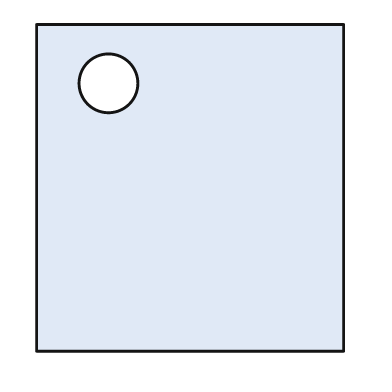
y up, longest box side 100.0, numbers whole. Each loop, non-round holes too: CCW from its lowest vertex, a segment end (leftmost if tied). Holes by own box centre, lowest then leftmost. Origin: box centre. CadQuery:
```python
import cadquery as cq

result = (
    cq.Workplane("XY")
    .moveTo(-47.0, -50.0)
    .lineTo(47.0, -50.0)
    .lineTo(47.0, 50.0)
    .lineTo(-47.0, 50.0)
    .close()
    .moveTo(-25.0, 32.0)
    .circle(9.0)
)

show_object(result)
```